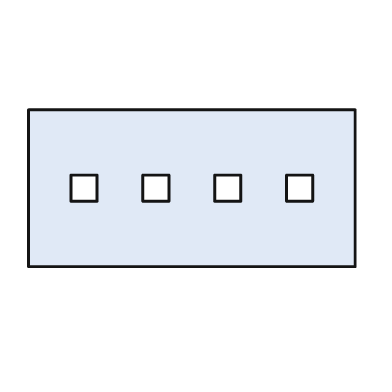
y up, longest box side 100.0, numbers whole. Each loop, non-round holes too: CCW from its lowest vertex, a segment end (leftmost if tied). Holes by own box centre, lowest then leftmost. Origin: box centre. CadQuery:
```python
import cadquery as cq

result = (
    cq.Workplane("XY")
    .moveTo(-50.0, -24.0)
    .lineTo(50.0, -24.0)
    .lineTo(50.0, 24.0)
    .lineTo(-50.0, 24.0)
    .close()
    .moveTo(-37.0, -4.0)
    .lineTo(-29.0, -4.0)
    .lineTo(-29.0, 4.0)
    .lineTo(-37.0, 4.0)
    .close()
    .moveTo(-15.0, -4.0)
    .lineTo(-7.0, -4.0)
    .lineTo(-7.0, 4.0)
    .lineTo(-15.0, 4.0)
    .close()
    .moveTo(7.0, -4.0)
    .lineTo(15.0, -4.0)
    .lineTo(15.0, 4.0)
    .lineTo(7.0, 4.0)
    .close()
    .moveTo(29.0, -4.0)
    .lineTo(37.0, -4.0)
    .lineTo(37.0, 4.0)
    .lineTo(29.0, 4.0)
    .close()
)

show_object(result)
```